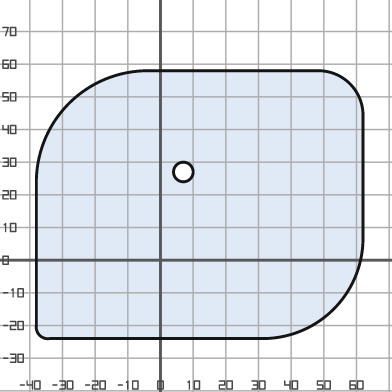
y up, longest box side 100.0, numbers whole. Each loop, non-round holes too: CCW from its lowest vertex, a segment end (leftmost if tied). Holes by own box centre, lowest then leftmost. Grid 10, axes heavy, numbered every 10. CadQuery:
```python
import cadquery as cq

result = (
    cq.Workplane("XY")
    .moveTo(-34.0, -24.0)
    .lineTo(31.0, -24.0)
    .threePointArc((53.0, -15.0), (62.0, 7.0))
    .lineTo(62.0, 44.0)
    .threePointArc((58.0, 54.0), (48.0, 58.0))
    .lineTo(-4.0, 58.0)
    .threePointArc((-28.0, 48.0), (-38.0, 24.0))
    .lineTo(-38.0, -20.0)
    .threePointArc((-37.0, -23.0), (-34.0, -24.0))
    .close()
    .moveTo(7.0, 27.0)
    .circle(3.0)
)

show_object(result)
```